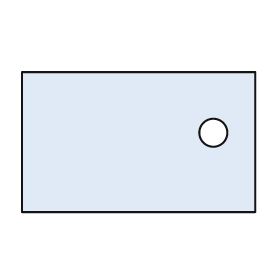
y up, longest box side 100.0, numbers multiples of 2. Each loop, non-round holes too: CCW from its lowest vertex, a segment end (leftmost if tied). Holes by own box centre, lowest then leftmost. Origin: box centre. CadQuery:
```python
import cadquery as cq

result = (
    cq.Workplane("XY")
    .moveTo(-50.0, -30.0)
    .lineTo(50.0, -30.0)
    .lineTo(50.0, 30.0)
    .lineTo(-50.0, 30.0)
    .close()
    .moveTo(32.0, 4.0)
    .circle(6.0)
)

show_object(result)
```